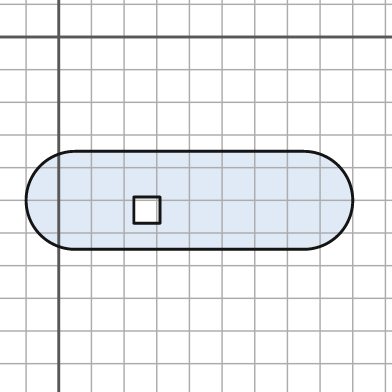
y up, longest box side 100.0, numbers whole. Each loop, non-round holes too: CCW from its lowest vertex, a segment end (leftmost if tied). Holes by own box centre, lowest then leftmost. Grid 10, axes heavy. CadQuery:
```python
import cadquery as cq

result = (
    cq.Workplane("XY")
    .moveTo(5.0, -65.0)
    .lineTo(75.0, -65.0)
    .threePointArc((90.0, -50.0), (75.0, -35.0))
    .lineTo(5.0, -35.0)
    .threePointArc((-10.0, -50.0), (5.0, -65.0))
    .close()
    .moveTo(23.0, -57.0)
    .lineTo(31.0, -57.0)
    .lineTo(31.0, -49.0)
    .lineTo(23.0, -49.0)
    .close()
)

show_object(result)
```